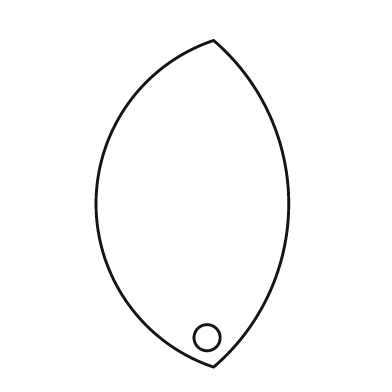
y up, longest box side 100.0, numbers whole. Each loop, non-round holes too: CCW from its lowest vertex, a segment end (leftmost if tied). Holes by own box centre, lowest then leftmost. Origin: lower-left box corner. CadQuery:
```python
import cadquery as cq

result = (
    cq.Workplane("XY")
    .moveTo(36.0, 0.0)
    .threePointArc((59.0, 50.0), (36.0, 100.0))
    .threePointArc((0.0, 50.0), (36.0, 0.0))
    .close()
    .moveTo(34.0, 9.0)
    .circle(4.0)
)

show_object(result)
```